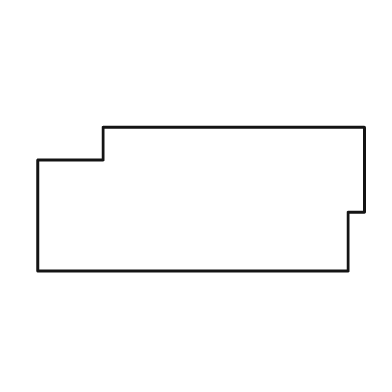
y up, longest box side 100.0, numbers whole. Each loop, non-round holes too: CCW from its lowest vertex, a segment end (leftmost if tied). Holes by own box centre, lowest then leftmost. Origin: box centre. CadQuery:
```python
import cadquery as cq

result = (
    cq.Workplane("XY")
    .moveTo(-50.0, -22.0)
    .lineTo(45.0, -22.0)
    .lineTo(45.0, -4.0)
    .lineTo(50.0, -4.0)
    .lineTo(50.0, 22.0)
    .lineTo(-30.0, 22.0)
    .lineTo(-30.0, 12.0)
    .lineTo(-50.0, 12.0)
    .close()
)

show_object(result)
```